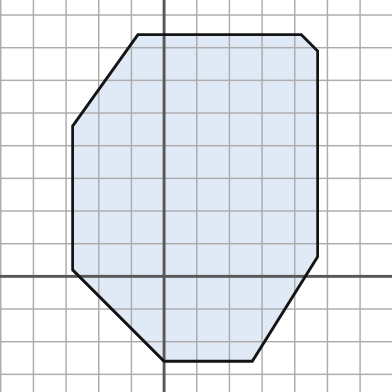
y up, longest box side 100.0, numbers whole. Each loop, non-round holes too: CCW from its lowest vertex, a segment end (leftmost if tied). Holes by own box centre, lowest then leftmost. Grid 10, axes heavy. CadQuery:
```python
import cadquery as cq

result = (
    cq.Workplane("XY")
    .moveTo(0.0, -26.0)
    .lineTo(27.0, -26.0)
    .lineTo(47.0, 6.0)
    .lineTo(47.0, 69.0)
    .lineTo(42.0, 74.0)
    .lineTo(-8.0, 74.0)
    .lineTo(-28.0, 46.0)
    .lineTo(-28.0, 2.0)
    .close()
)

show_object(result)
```